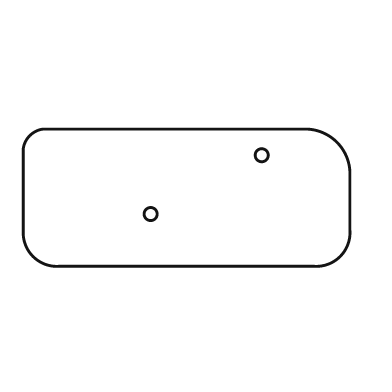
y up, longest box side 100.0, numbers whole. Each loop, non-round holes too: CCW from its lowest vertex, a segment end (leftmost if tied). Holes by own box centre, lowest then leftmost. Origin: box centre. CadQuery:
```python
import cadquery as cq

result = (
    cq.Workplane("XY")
    .moveTo(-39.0, -21.0)
    .lineTo(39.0, -21.0)
    .threePointArc((47.0, -18.0), (50.0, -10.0))
    .lineTo(50.0, 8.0)
    .threePointArc((46.0, 17.0), (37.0, 21.0))
    .lineTo(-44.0, 21.0)
    .threePointArc((-48.0, 19.0), (-50.0, 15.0))
    .lineTo(-50.0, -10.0)
    .threePointArc((-47.0, -18.0), (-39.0, -21.0))
    .close()
    .moveTo(-11.0, -5.0)
    .circle(2.0)
    .moveTo(23.0, 13.0)
    .circle(2.0)
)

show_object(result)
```